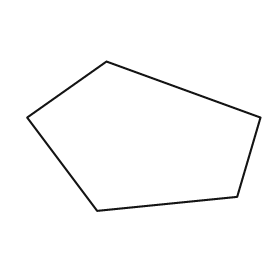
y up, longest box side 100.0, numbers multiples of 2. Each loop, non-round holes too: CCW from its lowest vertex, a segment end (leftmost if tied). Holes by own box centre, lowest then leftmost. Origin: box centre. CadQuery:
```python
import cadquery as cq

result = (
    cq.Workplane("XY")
    .moveTo(-20.0, -32.0)
    .lineTo(40.0, -26.0)
    .lineTo(50.0, 8.0)
    .lineTo(-16.0, 32.0)
    .lineTo(-50.0, 8.0)
    .close()
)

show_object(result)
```